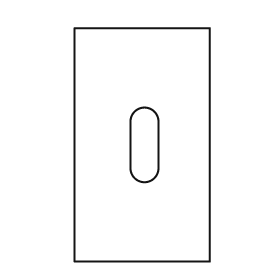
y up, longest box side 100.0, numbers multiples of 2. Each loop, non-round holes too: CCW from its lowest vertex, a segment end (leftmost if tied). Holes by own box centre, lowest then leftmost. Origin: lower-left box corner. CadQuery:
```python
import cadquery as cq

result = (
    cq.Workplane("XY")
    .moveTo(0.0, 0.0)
    .lineTo(58.0, 0.0)
    .lineTo(58.0, 100.0)
    .lineTo(0.0, 100.0)
    .close()
    .moveTo(24.0, 40.0)
    .threePointArc((30.0, 34.0), (36.0, 40.0))
    .lineTo(36.0, 60.0)
    .threePointArc((30.0, 66.0), (24.0, 60.0))
    .close()
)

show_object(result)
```